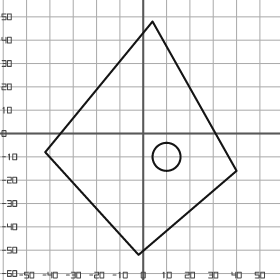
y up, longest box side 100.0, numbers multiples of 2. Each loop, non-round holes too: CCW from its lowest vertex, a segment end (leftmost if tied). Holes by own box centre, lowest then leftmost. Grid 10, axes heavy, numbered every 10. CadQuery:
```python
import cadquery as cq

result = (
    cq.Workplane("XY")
    .moveTo(-2.0, -52.0)
    .lineTo(40.0, -16.0)
    .lineTo(4.0, 48.0)
    .lineTo(-42.0, -8.0)
    .close()
    .moveTo(10.0, -10.0)
    .circle(6.0)
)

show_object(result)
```